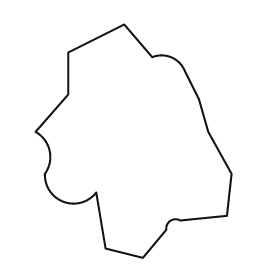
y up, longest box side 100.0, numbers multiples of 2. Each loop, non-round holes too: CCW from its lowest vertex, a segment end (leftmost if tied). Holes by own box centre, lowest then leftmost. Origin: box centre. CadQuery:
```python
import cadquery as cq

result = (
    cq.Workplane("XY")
    .moveTo(4.0, -50.0)
    .lineTo(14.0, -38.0)
    .threePointArc((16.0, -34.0), (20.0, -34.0))
    .lineTo(40.0, -32.0)
    .lineTo(42.0, -14.0)
    .lineTo(32.0, 4.0)
    .lineTo(28.0, 18.0)
    .lineTo(22.0, 30.0)
    .threePointArc((16.0, 36.0), (8.0, 36.0))
    .lineTo(-4.0, 50.0)
    .lineTo(-28.0, 38.0)
    .lineTo(-28.0, 20.0)
    .lineTo(-42.0, 4.0)
    .threePointArc((-36.0, -4.0), (-38.0, -14.0))
    .threePointArc((-30.0, -26.0), (-16.0, -22.0))
    .lineTo(-12.0, -46.0)
    .close()
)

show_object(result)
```